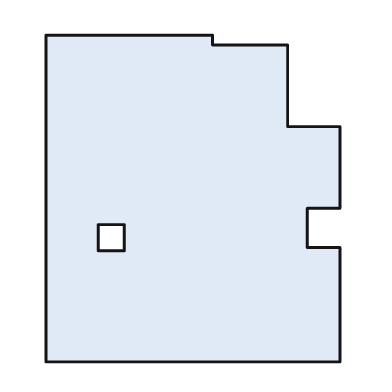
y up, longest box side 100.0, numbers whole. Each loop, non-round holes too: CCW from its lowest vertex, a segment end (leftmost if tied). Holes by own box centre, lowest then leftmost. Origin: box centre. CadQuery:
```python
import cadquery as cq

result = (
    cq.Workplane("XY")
    .moveTo(-45.0, -50.0)
    .lineTo(45.0, -50.0)
    .lineTo(45.0, -15.0)
    .lineTo(35.0, -15.0)
    .lineTo(35.0, -3.0)
    .lineTo(45.0, -3.0)
    .lineTo(45.0, 22.0)
    .lineTo(29.0, 22.0)
    .lineTo(29.0, 47.0)
    .lineTo(6.0, 47.0)
    .lineTo(6.0, 50.0)
    .lineTo(-45.0, 50.0)
    .close()
    .moveTo(-29.0, -16.0)
    .lineTo(-21.0, -16.0)
    .lineTo(-21.0, -8.0)
    .lineTo(-29.0, -8.0)
    .close()
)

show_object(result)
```